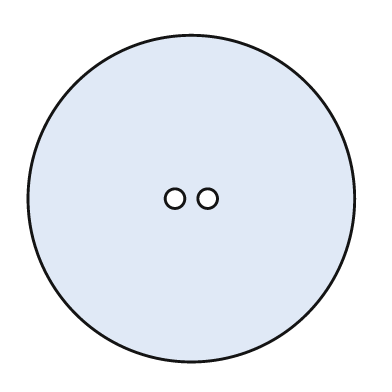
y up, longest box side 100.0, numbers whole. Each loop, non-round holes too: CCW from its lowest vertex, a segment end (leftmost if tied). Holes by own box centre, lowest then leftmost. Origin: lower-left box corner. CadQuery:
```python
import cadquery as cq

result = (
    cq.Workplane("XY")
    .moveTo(50.0, 50.0)
    .circle(50.0)
    .moveTo(45.0, 50.0)
    .circle(3.0)
    .moveTo(55.0, 50.0)
    .circle(3.0)
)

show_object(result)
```